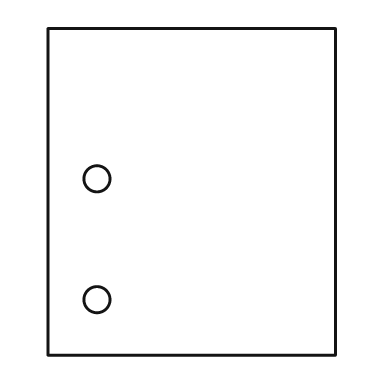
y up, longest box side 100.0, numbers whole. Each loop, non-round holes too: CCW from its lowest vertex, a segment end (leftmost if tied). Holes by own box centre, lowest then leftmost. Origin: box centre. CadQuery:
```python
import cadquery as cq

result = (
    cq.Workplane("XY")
    .moveTo(-44.0, -50.0)
    .lineTo(44.0, -50.0)
    .lineTo(44.0, 50.0)
    .lineTo(-44.0, 50.0)
    .close()
    .moveTo(-29.0, -33.0)
    .circle(4.0)
    .moveTo(-29.0, 4.0)
    .circle(4.0)
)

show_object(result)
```